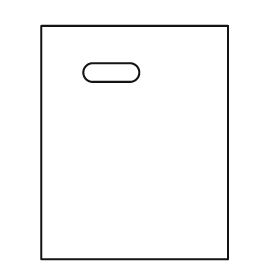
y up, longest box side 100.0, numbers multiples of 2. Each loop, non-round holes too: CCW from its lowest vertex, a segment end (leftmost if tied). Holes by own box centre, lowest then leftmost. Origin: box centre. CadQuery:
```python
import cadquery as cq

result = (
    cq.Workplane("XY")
    .moveTo(-40.0, -50.0)
    .lineTo(40.0, -50.0)
    .lineTo(40.0, 50.0)
    .lineTo(-40.0, 50.0)
    .close()
    .moveTo(-18.0, 26.0)
    .lineTo(-2.0, 26.0)
    .threePointArc((2.0, 30.0), (-2.0, 34.0))
    .lineTo(-18.0, 34.0)
    .threePointArc((-22.0, 30.0), (-18.0, 26.0))
    .close()
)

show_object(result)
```